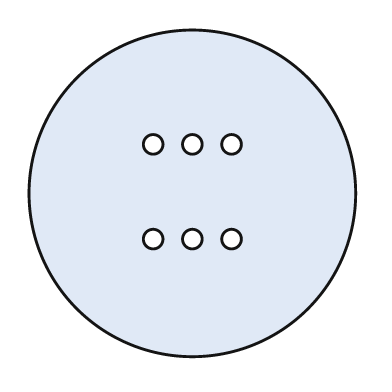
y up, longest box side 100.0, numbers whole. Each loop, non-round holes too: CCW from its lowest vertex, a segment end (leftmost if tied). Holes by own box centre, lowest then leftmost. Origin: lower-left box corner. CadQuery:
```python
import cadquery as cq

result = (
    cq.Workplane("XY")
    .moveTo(50.0, 50.0)
    .circle(50.0)
    .moveTo(38.0, 36.0)
    .circle(3.0)
    .moveTo(50.0, 36.0)
    .circle(3.0)
    .moveTo(62.0, 36.0)
    .circle(3.0)
    .moveTo(38.0, 65.0)
    .circle(3.0)
    .moveTo(50.0, 65.0)
    .circle(3.0)
    .moveTo(62.0, 65.0)
    .circle(3.0)
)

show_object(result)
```